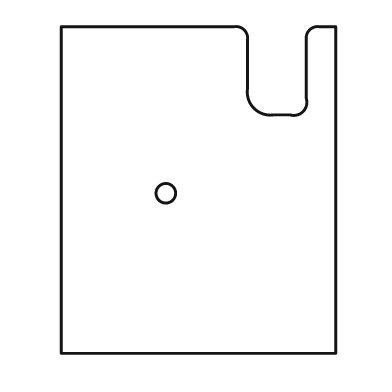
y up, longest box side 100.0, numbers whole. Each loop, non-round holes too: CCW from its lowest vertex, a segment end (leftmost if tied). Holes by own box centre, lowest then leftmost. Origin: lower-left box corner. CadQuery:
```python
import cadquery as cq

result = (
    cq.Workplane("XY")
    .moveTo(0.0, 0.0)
    .lineTo(84.0, 0.0)
    .lineTo(84.0, 100.0)
    .lineTo(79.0, 100.0)
    .threePointArc((76.0, 99.0), (75.0, 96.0))
    .lineTo(75.0, 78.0)
    .threePointArc((74.0, 74.0), (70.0, 73.0))
    .lineTo(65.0, 73.0)
    .threePointArc((59.0, 75.0), (57.0, 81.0))
    .lineTo(57.0, 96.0)
    .threePointArc((56.0, 99.0), (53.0, 100.0))
    .lineTo(0.0, 100.0)
    .close()
    .moveTo(32.0, 49.0)
    .circle(3.0)
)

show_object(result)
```